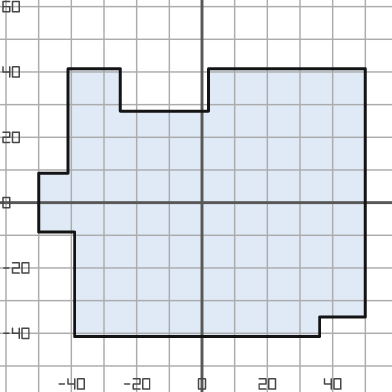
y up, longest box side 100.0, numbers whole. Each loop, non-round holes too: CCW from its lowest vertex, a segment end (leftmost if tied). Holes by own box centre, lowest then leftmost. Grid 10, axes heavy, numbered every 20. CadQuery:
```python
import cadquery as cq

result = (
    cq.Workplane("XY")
    .moveTo(-39.0, -41.0)
    .lineTo(36.0, -41.0)
    .lineTo(36.0, -35.0)
    .lineTo(50.0, -35.0)
    .lineTo(50.0, 41.0)
    .lineTo(2.0, 41.0)
    .lineTo(2.0, 28.0)
    .lineTo(-25.0, 28.0)
    .lineTo(-25.0, 41.0)
    .lineTo(-41.0, 41.0)
    .lineTo(-41.0, 9.0)
    .lineTo(-50.0, 9.0)
    .lineTo(-50.0, -9.0)
    .lineTo(-39.0, -9.0)
    .close()
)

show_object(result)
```